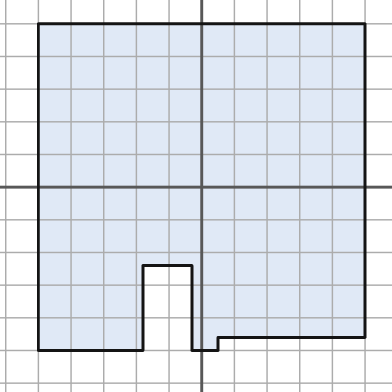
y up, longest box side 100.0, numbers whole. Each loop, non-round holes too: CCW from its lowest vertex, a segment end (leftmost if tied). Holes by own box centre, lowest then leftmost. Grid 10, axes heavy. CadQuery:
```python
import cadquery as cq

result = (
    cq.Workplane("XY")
    .moveTo(-50.0, -50.0)
    .lineTo(-18.0, -50.0)
    .lineTo(-18.0, -24.0)
    .lineTo(-3.0, -24.0)
    .lineTo(-3.0, -50.0)
    .lineTo(5.0, -50.0)
    .lineTo(5.0, -46.0)
    .lineTo(50.0, -46.0)
    .lineTo(50.0, 50.0)
    .lineTo(-50.0, 50.0)
    .close()
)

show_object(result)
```